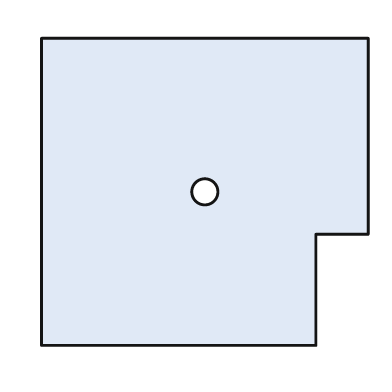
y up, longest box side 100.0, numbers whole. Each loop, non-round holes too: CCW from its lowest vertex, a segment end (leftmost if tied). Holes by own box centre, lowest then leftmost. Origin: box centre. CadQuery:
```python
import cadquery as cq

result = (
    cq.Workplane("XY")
    .moveTo(-50.0, -47.0)
    .lineTo(34.0, -47.0)
    .lineTo(34.0, -13.0)
    .lineTo(50.0, -13.0)
    .lineTo(50.0, 47.0)
    .lineTo(-50.0, 47.0)
    .close()
    .moveTo(0.0, 0.0)
    .circle(4.0)
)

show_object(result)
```